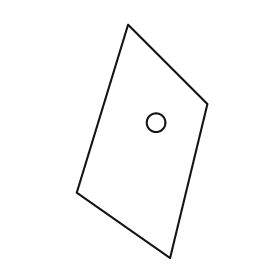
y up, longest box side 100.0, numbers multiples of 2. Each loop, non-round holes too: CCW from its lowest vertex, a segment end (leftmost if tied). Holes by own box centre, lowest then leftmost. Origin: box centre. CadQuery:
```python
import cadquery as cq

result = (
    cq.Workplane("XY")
    .moveTo(12.0, -50.0)
    .lineTo(28.0, 16.0)
    .lineTo(-6.0, 50.0)
    .lineTo(-28.0, -22.0)
    .close()
    .moveTo(6.0, 8.0)
    .circle(4.0)
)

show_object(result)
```